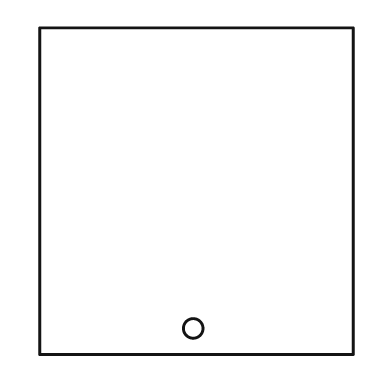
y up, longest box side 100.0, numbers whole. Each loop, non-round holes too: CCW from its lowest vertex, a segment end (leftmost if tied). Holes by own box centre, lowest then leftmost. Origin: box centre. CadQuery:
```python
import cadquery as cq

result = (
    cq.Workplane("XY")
    .moveTo(-48.0, -50.0)
    .lineTo(48.0, -50.0)
    .lineTo(48.0, 50.0)
    .lineTo(-48.0, 50.0)
    .close()
    .moveTo(-1.0, -42.0)
    .circle(3.0)
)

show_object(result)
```